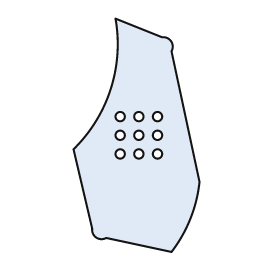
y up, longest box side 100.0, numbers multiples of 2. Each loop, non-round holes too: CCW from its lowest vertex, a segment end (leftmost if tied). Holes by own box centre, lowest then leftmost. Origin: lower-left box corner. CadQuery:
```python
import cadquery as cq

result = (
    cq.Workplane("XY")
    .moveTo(42.0, 0.0)
    .threePointArc((50.0, 14.0), (54.0, 30.0))
    .lineTo(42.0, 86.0)
    .threePointArc((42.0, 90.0), (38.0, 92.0))
    .lineTo(18.0, 100.0)
    .threePointArc((16.0, 70.0), (0.0, 44.0))
    .lineTo(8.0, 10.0)
    .threePointArc((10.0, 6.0), (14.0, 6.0))
    .close()
    .moveTo(20.0, 42.0)
    .circle(2.0)
    .moveTo(28.0, 42.0)
    .circle(2.0)
    .moveTo(36.0, 42.0)
    .circle(2.0)
    .moveTo(20.0, 50.0)
    .circle(2.0)
    .moveTo(28.0, 50.0)
    .circle(2.0)
    .moveTo(36.0, 50.0)
    .circle(2.0)
    .moveTo(20.0, 58.0)
    .circle(2.0)
    .moveTo(28.0, 58.0)
    .circle(2.0)
    .moveTo(36.0, 58.0)
    .circle(2.0)
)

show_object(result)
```